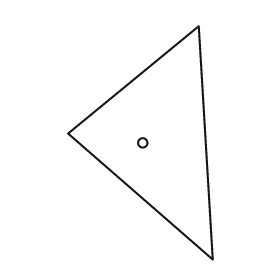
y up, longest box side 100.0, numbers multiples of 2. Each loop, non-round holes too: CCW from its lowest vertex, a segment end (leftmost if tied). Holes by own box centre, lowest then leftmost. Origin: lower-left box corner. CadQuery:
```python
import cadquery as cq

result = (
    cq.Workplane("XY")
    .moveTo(62.0, 0.0)
    .lineTo(56.0, 100.0)
    .lineTo(0.0, 54.0)
    .close()
    .moveTo(32.0, 50.0)
    .circle(2.0)
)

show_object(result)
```